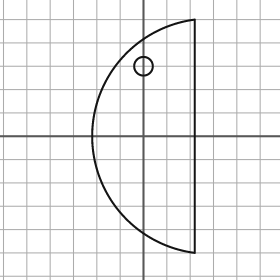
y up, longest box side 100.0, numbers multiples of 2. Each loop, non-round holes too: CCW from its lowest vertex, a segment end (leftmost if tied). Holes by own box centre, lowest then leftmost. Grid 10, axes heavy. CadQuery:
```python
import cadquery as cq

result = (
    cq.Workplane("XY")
    .moveTo(22.0, -50.0)
    .lineTo(22.0, 50.0)
    .threePointArc((-22.0, 0.0), (22.0, -50.0))
    .close()
    .moveTo(0.0, 30.0)
    .circle(4.0)
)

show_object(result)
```